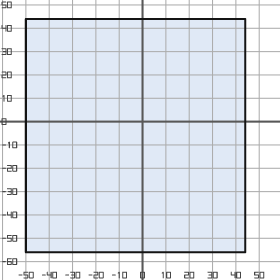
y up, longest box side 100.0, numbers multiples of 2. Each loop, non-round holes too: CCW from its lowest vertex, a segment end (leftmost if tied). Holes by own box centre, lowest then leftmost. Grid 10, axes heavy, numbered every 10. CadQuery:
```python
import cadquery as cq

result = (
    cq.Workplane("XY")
    .moveTo(-50.0, -56.0)
    .lineTo(44.0, -56.0)
    .lineTo(44.0, 44.0)
    .lineTo(-50.0, 44.0)
    .close()
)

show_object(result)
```